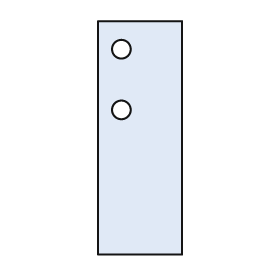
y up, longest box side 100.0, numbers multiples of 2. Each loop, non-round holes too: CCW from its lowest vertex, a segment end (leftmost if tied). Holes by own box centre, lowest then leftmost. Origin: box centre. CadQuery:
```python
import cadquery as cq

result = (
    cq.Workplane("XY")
    .moveTo(-18.0, -50.0)
    .lineTo(18.0, -50.0)
    .lineTo(18.0, 50.0)
    .lineTo(-18.0, 50.0)
    .close()
    .moveTo(-8.0, 12.0)
    .circle(4.0)
    .moveTo(-8.0, 38.0)
    .circle(4.0)
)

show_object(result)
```